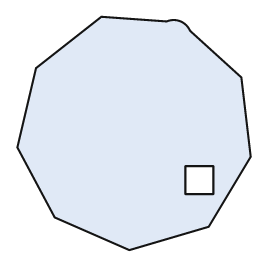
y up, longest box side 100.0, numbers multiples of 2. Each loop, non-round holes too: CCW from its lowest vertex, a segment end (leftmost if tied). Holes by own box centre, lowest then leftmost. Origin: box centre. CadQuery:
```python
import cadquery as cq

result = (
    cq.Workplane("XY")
    .moveTo(-2.0, -50.0)
    .lineTo(32.0, -40.0)
    .lineTo(50.0, -10.0)
    .lineTo(46.0, 24.0)
    .lineTo(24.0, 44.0)
    .threePointArc((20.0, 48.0), (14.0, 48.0))
    .lineTo(-14.0, 50.0)
    .lineTo(-42.0, 28.0)
    .lineTo(-50.0, -6.0)
    .lineTo(-34.0, -36.0)
    .close()
    .moveTo(22.0, -26.0)
    .lineTo(34.0, -26.0)
    .lineTo(34.0, -14.0)
    .lineTo(22.0, -14.0)
    .close()
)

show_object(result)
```